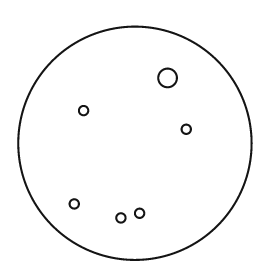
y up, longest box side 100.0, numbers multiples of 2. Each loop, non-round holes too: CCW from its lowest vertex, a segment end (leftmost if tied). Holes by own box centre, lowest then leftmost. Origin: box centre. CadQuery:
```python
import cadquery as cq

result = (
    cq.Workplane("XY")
    .moveTo(0.0, 0.0)
    .circle(50.0)
    .moveTo(-6.0, -32.0)
    .circle(2.0)
    .moveTo(2.0, -30.0)
    .circle(2.0)
    .moveTo(-26.0, -26.0)
    .circle(2.0)
    .moveTo(22.0, 6.0)
    .circle(2.0)
    .moveTo(-22.0, 14.0)
    .circle(2.0)
    .moveTo(14.0, 28.0)
    .circle(4.0)
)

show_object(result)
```